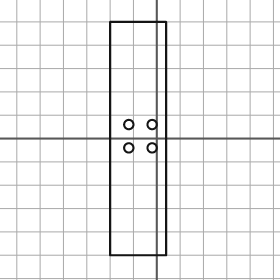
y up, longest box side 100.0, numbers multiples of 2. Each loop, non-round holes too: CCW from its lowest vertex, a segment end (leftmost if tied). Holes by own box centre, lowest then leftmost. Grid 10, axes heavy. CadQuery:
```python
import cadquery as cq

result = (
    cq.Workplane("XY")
    .moveTo(-20.0, -50.0)
    .lineTo(4.0, -50.0)
    .lineTo(4.0, 50.0)
    .lineTo(-20.0, 50.0)
    .close()
    .moveTo(-12.0, -4.0)
    .circle(2.0)
    .moveTo(-2.0, -4.0)
    .circle(2.0)
    .moveTo(-12.0, 6.0)
    .circle(2.0)
    .moveTo(-2.0, 6.0)
    .circle(2.0)
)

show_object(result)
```